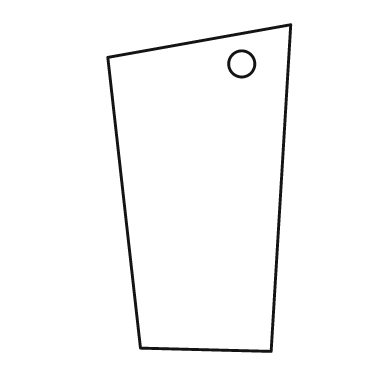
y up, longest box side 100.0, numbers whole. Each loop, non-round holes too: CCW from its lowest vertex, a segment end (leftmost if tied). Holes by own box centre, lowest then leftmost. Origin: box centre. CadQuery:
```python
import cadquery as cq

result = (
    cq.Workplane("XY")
    .moveTo(22.0, -50.0)
    .lineTo(28.0, 50.0)
    .lineTo(-28.0, 40.0)
    .lineTo(-18.0, -49.0)
    .close()
    .moveTo(13.0, 38.0)
    .circle(4.0)
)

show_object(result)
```